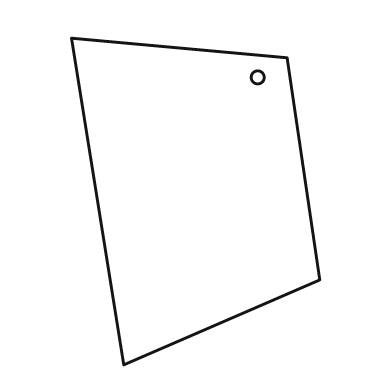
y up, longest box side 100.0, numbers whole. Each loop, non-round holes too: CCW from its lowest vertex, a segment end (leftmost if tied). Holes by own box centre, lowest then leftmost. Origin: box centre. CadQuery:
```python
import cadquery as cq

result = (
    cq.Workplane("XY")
    .moveTo(-22.0, -50.0)
    .lineTo(38.0, -24.0)
    .lineTo(28.0, 44.0)
    .lineTo(-38.0, 50.0)
    .close()
    .moveTo(19.0, 38.0)
    .circle(2.0)
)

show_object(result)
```